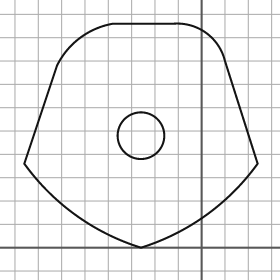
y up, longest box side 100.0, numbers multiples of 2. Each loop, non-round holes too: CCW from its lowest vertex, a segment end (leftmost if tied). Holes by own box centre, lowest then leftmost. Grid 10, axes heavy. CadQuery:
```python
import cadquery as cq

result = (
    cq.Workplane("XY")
    .moveTo(-26.0, 0.0)
    .threePointArc((2.0, 14.0), (24.0, 36.0))
    .lineTo(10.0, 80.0)
    .threePointArc((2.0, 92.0), (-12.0, 96.0))
    .lineTo(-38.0, 96.0)
    .threePointArc((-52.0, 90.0), (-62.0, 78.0))
    .lineTo(-76.0, 36.0)
    .threePointArc((-54.0, 14.0), (-26.0, 0.0))
    .close()
    .moveTo(-26.0, 48.0)
    .circle(10.0)
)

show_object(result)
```